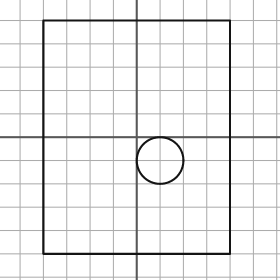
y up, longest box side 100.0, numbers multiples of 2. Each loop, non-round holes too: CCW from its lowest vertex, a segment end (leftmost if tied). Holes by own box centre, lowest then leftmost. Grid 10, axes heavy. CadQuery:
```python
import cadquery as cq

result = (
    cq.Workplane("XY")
    .moveTo(-40.0, -50.0)
    .lineTo(40.0, -50.0)
    .lineTo(40.0, 50.0)
    .lineTo(-40.0, 50.0)
    .close()
    .moveTo(10.0, -10.0)
    .circle(10.0)
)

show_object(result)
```